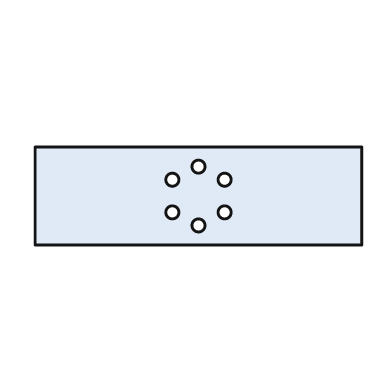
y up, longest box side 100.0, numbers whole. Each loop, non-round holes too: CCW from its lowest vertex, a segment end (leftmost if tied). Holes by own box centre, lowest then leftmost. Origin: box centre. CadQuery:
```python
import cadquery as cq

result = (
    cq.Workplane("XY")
    .moveTo(-50.0, -15.0)
    .lineTo(50.0, -15.0)
    .lineTo(50.0, 15.0)
    .lineTo(-50.0, 15.0)
    .close()
    .moveTo(0.0, -9.0)
    .circle(2.0)
    .moveTo(-8.0, -5.0)
    .circle(2.0)
    .moveTo(8.0, -5.0)
    .circle(2.0)
    .moveTo(-8.0, 5.0)
    .circle(2.0)
    .moveTo(8.0, 5.0)
    .circle(2.0)
    .moveTo(0.0, 9.0)
    .circle(2.0)
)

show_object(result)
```